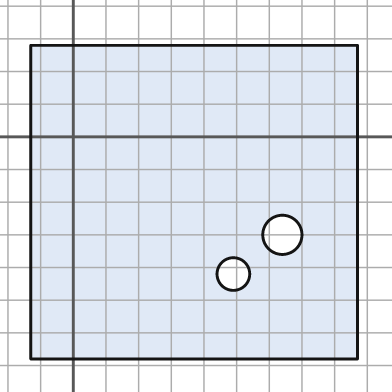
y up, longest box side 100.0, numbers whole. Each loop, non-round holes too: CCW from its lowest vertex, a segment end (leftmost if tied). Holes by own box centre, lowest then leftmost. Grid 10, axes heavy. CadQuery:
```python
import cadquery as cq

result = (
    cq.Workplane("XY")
    .moveTo(-13.0, -68.0)
    .lineTo(87.0, -68.0)
    .lineTo(87.0, 28.0)
    .lineTo(-13.0, 28.0)
    .close()
    .moveTo(49.0, -42.0)
    .circle(5.0)
    .moveTo(64.0, -30.0)
    .circle(6.0)
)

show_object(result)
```